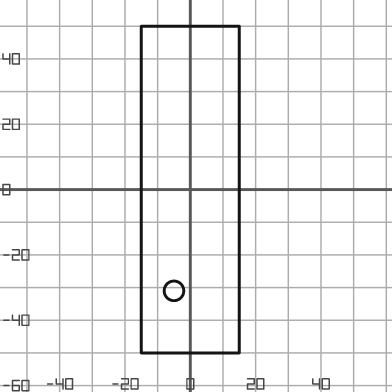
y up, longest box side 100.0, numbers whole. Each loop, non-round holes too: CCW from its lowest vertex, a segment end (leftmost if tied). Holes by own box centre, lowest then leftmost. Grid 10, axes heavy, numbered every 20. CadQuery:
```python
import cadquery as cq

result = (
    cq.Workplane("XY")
    .moveTo(-15.0, -50.0)
    .lineTo(15.0, -50.0)
    .lineTo(15.0, 50.0)
    .lineTo(-15.0, 50.0)
    .close()
    .moveTo(-5.0, -31.0)
    .circle(3.0)
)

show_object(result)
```